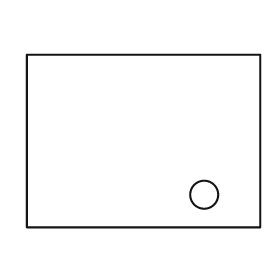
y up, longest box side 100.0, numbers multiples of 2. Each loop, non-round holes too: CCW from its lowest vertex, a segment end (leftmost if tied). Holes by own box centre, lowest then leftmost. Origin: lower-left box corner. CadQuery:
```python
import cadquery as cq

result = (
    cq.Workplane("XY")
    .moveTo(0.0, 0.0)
    .lineTo(100.0, 0.0)
    .lineTo(100.0, 74.0)
    .lineTo(0.0, 74.0)
    .close()
    .moveTo(76.0, 14.0)
    .circle(6.0)
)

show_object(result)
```